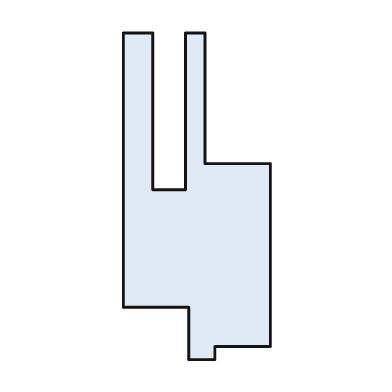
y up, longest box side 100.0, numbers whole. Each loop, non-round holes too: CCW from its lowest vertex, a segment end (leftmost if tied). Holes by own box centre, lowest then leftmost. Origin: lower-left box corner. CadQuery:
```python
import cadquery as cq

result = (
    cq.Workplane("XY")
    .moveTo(20.0, 0.0)
    .lineTo(28.0, 0.0)
    .lineTo(28.0, 4.0)
    .lineTo(45.0, 4.0)
    .lineTo(45.0, 60.0)
    .lineTo(25.0, 60.0)
    .lineTo(25.0, 100.0)
    .lineTo(19.0, 100.0)
    .lineTo(19.0, 52.0)
    .lineTo(9.0, 52.0)
    .lineTo(9.0, 100.0)
    .lineTo(0.0, 100.0)
    .lineTo(0.0, 16.0)
    .lineTo(20.0, 16.0)
    .close()
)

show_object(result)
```